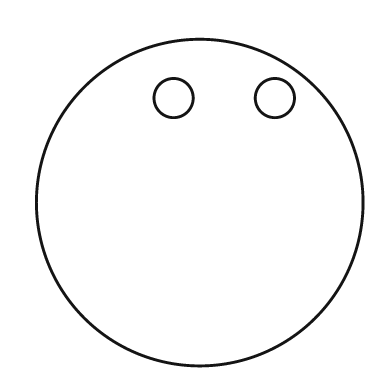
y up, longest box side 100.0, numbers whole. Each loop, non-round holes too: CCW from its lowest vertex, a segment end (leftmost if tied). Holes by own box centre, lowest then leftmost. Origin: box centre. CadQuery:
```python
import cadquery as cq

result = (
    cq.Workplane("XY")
    .moveTo(0.0, 0.0)
    .circle(50.0)
    .moveTo(-8.0, 32.0)
    .circle(6.0)
    .moveTo(23.0, 32.0)
    .circle(6.0)
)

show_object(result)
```